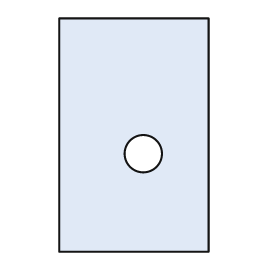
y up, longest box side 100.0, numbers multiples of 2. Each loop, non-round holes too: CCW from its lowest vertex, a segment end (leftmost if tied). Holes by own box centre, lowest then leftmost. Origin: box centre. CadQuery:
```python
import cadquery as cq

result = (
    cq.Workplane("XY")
    .moveTo(-32.0, -50.0)
    .lineTo(32.0, -50.0)
    .lineTo(32.0, 50.0)
    .lineTo(-32.0, 50.0)
    .close()
    .moveTo(4.0, -8.0)
    .circle(8.0)
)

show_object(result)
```